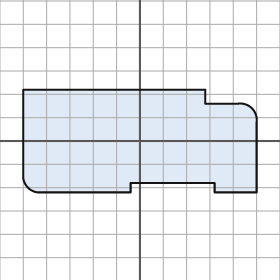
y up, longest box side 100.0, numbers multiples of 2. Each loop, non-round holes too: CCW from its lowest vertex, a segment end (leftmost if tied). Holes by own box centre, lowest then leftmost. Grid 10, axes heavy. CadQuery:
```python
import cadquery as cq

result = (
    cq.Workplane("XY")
    .moveTo(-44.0, -22.0)
    .lineTo(-4.0, -22.0)
    .lineTo(-4.0, -18.0)
    .lineTo(32.0, -18.0)
    .lineTo(32.0, -22.0)
    .lineTo(50.0, -22.0)
    .lineTo(50.0, 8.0)
    .threePointArc((48.0, 14.0), (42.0, 16.0))
    .lineTo(28.0, 16.0)
    .lineTo(28.0, 22.0)
    .lineTo(-50.0, 22.0)
    .lineTo(-50.0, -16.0)
    .threePointArc((-48.0, -20.0), (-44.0, -22.0))
    .close()
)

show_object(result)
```